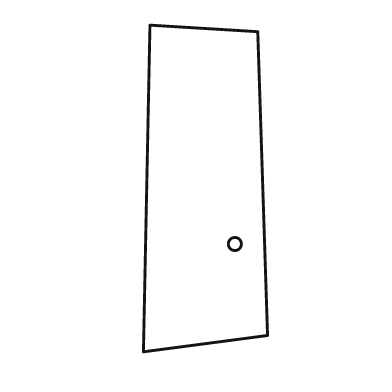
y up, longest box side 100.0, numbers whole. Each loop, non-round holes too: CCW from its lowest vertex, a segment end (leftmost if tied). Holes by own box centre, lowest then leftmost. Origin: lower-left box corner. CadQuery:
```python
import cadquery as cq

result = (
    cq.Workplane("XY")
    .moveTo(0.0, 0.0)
    .lineTo(38.0, 5.0)
    .lineTo(35.0, 98.0)
    .lineTo(2.0, 100.0)
    .close()
    .moveTo(28.0, 33.0)
    .circle(2.0)
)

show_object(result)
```